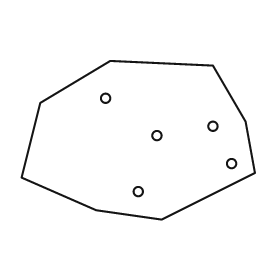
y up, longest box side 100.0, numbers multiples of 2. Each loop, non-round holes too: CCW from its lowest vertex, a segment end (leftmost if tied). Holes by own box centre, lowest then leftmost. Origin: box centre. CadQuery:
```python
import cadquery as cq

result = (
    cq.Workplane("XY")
    .moveTo(10.0, -34.0)
    .lineTo(50.0, -14.0)
    .lineTo(46.0, 8.0)
    .lineTo(32.0, 32.0)
    .lineTo(-12.0, 34.0)
    .lineTo(-42.0, 16.0)
    .lineTo(-50.0, -16.0)
    .lineTo(-18.0, -30.0)
    .close()
    .moveTo(0.0, -22.0)
    .circle(2.0)
    .moveTo(40.0, -10.0)
    .circle(2.0)
    .moveTo(8.0, 2.0)
    .circle(2.0)
    .moveTo(32.0, 6.0)
    .circle(2.0)
    .moveTo(-14.0, 18.0)
    .circle(2.0)
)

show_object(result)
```